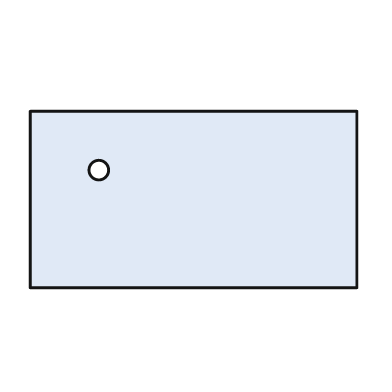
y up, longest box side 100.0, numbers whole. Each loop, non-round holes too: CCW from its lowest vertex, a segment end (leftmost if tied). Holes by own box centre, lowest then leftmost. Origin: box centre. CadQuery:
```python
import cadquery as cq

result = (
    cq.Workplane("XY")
    .moveTo(-50.0, -27.0)
    .lineTo(50.0, -27.0)
    .lineTo(50.0, 27.0)
    .lineTo(-50.0, 27.0)
    .close()
    .moveTo(-29.0, 9.0)
    .circle(3.0)
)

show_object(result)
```